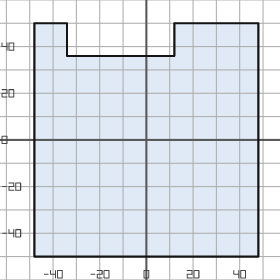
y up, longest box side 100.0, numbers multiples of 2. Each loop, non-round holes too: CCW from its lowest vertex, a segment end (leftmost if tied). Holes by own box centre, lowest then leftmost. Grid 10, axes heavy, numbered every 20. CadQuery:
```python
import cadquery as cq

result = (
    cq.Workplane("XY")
    .moveTo(-48.0, -50.0)
    .lineTo(48.0, -50.0)
    .lineTo(48.0, 50.0)
    .lineTo(12.0, 50.0)
    .lineTo(12.0, 36.0)
    .lineTo(-34.0, 36.0)
    .lineTo(-34.0, 50.0)
    .lineTo(-48.0, 50.0)
    .close()
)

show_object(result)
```